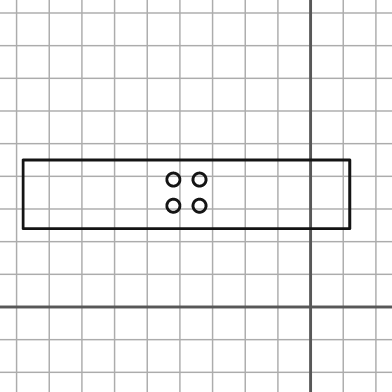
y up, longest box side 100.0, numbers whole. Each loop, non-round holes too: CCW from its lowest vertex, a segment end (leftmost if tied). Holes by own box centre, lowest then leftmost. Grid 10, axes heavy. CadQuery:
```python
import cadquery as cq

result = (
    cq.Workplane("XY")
    .moveTo(-88.0, 24.0)
    .lineTo(12.0, 24.0)
    .lineTo(12.0, 45.0)
    .lineTo(-88.0, 45.0)
    .close()
    .moveTo(-42.0, 31.0)
    .circle(2.0)
    .moveTo(-34.0, 31.0)
    .circle(2.0)
    .moveTo(-42.0, 39.0)
    .circle(2.0)
    .moveTo(-34.0, 39.0)
    .circle(2.0)
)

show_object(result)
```